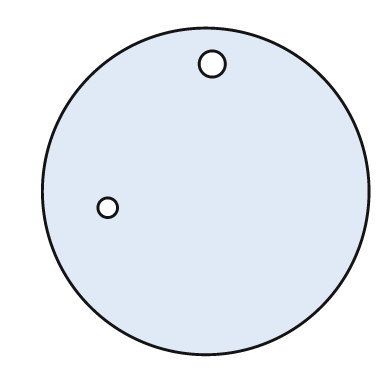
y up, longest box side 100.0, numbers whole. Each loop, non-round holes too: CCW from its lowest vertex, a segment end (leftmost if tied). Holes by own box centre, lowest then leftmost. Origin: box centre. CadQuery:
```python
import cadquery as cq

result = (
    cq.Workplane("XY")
    .moveTo(0.0, 0.0)
    .circle(50.0)
    .moveTo(-30.0, -5.0)
    .circle(3.0)
    .moveTo(2.0, 39.0)
    .circle(4.0)
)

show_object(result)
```